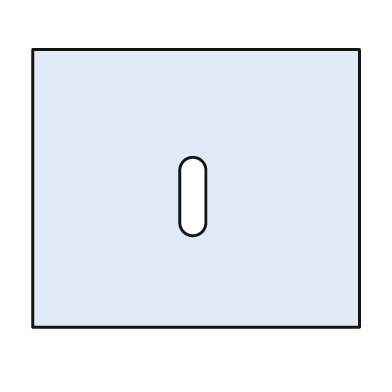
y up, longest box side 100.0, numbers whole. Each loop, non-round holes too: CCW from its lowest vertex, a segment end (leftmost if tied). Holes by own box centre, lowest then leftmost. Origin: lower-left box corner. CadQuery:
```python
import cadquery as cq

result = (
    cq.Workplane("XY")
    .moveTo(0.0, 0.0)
    .lineTo(100.0, 0.0)
    .lineTo(100.0, 85.0)
    .lineTo(0.0, 85.0)
    .close()
    .moveTo(45.0, 32.0)
    .threePointArc((49.0, 28.0), (53.0, 32.0))
    .lineTo(53.0, 48.0)
    .threePointArc((49.0, 52.0), (45.0, 48.0))
    .close()
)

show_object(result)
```